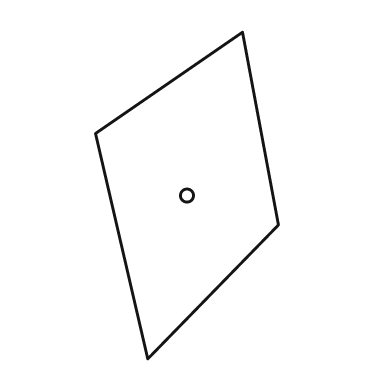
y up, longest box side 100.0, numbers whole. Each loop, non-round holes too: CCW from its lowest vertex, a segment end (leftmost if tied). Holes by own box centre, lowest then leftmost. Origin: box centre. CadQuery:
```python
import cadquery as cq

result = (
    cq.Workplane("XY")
    .moveTo(-12.0, -50.0)
    .lineTo(28.0, -9.0)
    .lineTo(17.0, 50.0)
    .lineTo(-28.0, 19.0)
    .close()
    .moveTo(0.0, 0.0)
    .circle(2.0)
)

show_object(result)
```